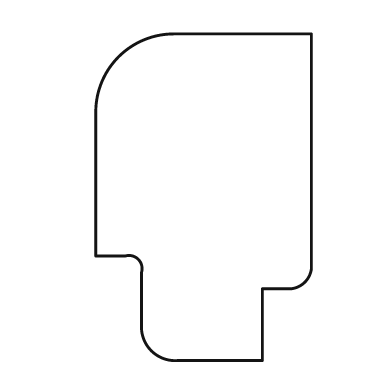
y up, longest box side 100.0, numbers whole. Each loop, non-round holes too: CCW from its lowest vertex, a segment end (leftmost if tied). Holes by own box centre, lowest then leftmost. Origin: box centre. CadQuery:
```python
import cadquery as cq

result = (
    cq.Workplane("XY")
    .moveTo(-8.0, -50.0)
    .lineTo(18.0, -50.0)
    .lineTo(18.0, -28.0)
    .lineTo(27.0, -28.0)
    .threePointArc((31.0, -26.0), (33.0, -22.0))
    .lineTo(33.0, 50.0)
    .lineTo(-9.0, 50.0)
    .threePointArc((-26.0, 43.0), (-33.0, 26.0))
    .lineTo(-33.0, -18.0)
    .lineTo(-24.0, -18.0)
    .threePointArc((-20.0, -19.0), (-19.0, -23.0))
    .lineTo(-19.0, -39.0)
    .threePointArc((-16.0, -47.0), (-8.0, -50.0))
    .close()
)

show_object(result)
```